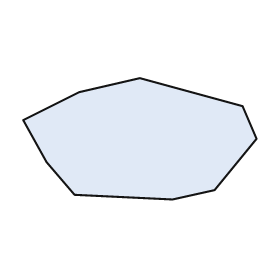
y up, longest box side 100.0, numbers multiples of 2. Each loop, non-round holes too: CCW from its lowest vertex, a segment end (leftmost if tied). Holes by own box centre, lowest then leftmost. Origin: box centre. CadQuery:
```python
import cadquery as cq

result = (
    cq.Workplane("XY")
    .moveTo(14.0, -26.0)
    .lineTo(32.0, -22.0)
    .lineTo(50.0, 0.0)
    .lineTo(44.0, 14.0)
    .lineTo(0.0, 26.0)
    .lineTo(-26.0, 20.0)
    .lineTo(-50.0, 8.0)
    .lineTo(-40.0, -10.0)
    .lineTo(-28.0, -24.0)
    .close()
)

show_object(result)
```